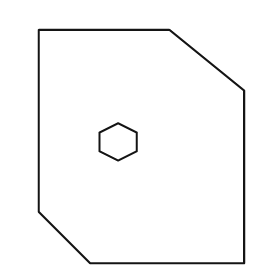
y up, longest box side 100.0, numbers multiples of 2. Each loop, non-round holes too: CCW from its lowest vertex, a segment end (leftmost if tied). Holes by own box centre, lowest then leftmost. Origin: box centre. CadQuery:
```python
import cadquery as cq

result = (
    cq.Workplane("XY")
    .moveTo(-22.0, -50.0)
    .lineTo(44.0, -50.0)
    .lineTo(44.0, 24.0)
    .lineTo(12.0, 50.0)
    .lineTo(-44.0, 50.0)
    .lineTo(-44.0, -28.0)
    .close()
    .moveTo(-10.0, -6.0)
    .lineTo(-2.0, -2.0)
    .lineTo(-2.0, 6.0)
    .lineTo(-10.0, 10.0)
    .lineTo(-18.0, 6.0)
    .lineTo(-18.0, -2.0)
    .close()
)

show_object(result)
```